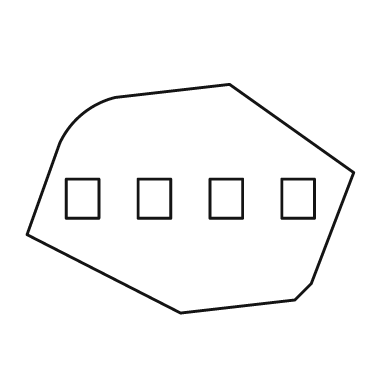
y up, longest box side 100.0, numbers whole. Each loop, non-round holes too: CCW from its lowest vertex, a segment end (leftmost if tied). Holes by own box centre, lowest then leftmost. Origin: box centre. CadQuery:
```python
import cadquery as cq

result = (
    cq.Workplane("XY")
    .moveTo(-3.0, -35.0)
    .lineTo(32.0, -31.0)
    .lineTo(37.0, -26.0)
    .lineTo(50.0, 8.0)
    .lineTo(12.0, 35.0)
    .lineTo(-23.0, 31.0)
    .threePointArc((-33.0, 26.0), (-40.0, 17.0))
    .lineTo(-50.0, -11.0)
    .close()
    .moveTo(-38.0, -6.0)
    .lineTo(-28.0, -6.0)
    .lineTo(-28.0, 6.0)
    .lineTo(-38.0, 6.0)
    .close()
    .moveTo(-16.0, -6.0)
    .lineTo(-6.0, -6.0)
    .lineTo(-6.0, 6.0)
    .lineTo(-16.0, 6.0)
    .close()
    .moveTo(6.0, -6.0)
    .lineTo(16.0, -6.0)
    .lineTo(16.0, 6.0)
    .lineTo(6.0, 6.0)
    .close()
    .moveTo(28.0, -6.0)
    .lineTo(38.0, -6.0)
    .lineTo(38.0, 6.0)
    .lineTo(28.0, 6.0)
    .close()
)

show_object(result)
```